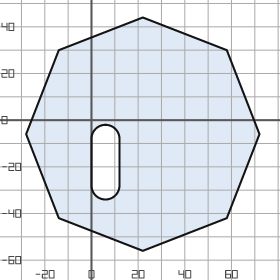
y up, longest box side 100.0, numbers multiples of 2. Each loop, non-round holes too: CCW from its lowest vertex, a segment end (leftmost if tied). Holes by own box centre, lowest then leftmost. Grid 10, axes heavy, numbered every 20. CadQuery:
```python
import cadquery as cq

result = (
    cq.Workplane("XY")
    .moveTo(22.0, -56.0)
    .lineTo(58.0, -42.0)
    .lineTo(72.0, -6.0)
    .lineTo(58.0, 30.0)
    .lineTo(22.0, 44.0)
    .lineTo(-14.0, 30.0)
    .lineTo(-28.0, -6.0)
    .lineTo(-14.0, -42.0)
    .close()
    .moveTo(0.0, -28.0)
    .threePointArc((6.0, -34.0), (12.0, -28.0))
    .lineTo(12.0, -8.0)
    .threePointArc((6.0, -2.0), (0.0, -8.0))
    .close()
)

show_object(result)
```